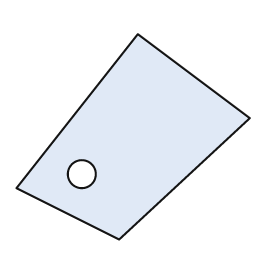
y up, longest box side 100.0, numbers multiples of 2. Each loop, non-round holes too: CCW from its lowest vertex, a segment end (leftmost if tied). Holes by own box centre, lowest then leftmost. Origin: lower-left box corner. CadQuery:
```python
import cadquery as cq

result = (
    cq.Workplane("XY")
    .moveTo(44.0, 0.0)
    .lineTo(100.0, 52.0)
    .lineTo(52.0, 88.0)
    .lineTo(0.0, 22.0)
    .close()
    .moveTo(28.0, 28.0)
    .circle(6.0)
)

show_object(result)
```